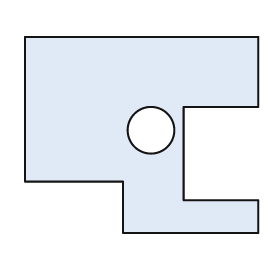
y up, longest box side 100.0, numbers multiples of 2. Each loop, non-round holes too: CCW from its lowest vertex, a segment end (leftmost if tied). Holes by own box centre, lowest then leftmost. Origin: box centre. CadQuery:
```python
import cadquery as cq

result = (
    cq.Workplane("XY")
    .moveTo(-8.0, -42.0)
    .lineTo(50.0, -42.0)
    .lineTo(50.0, -28.0)
    .lineTo(18.0, -28.0)
    .lineTo(18.0, 12.0)
    .lineTo(50.0, 12.0)
    .lineTo(50.0, 42.0)
    .lineTo(-50.0, 42.0)
    .lineTo(-50.0, -20.0)
    .lineTo(-8.0, -20.0)
    .close()
    .moveTo(4.0, 2.0)
    .circle(10.0)
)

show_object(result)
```